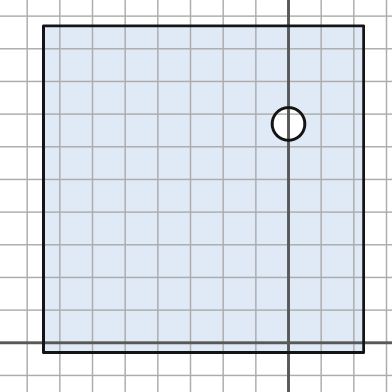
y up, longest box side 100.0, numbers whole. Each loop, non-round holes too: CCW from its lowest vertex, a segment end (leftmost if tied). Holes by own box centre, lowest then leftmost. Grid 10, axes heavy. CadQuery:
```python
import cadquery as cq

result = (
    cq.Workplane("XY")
    .moveTo(-75.0, -3.0)
    .lineTo(23.0, -3.0)
    .lineTo(23.0, 97.0)
    .lineTo(-75.0, 97.0)
    .close()
    .moveTo(0.0, 67.0)
    .circle(5.0)
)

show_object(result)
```